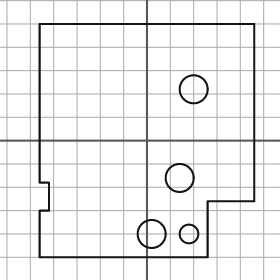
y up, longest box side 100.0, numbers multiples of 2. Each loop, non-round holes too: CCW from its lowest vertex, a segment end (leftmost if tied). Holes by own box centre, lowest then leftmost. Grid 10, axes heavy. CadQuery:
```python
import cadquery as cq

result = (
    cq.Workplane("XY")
    .moveTo(-46.0, -50.0)
    .lineTo(26.0, -50.0)
    .lineTo(26.0, -26.0)
    .lineTo(46.0, -26.0)
    .lineTo(46.0, 50.0)
    .lineTo(-46.0, 50.0)
    .lineTo(-46.0, -18.0)
    .lineTo(-42.0, -18.0)
    .lineTo(-42.0, -30.0)
    .lineTo(-46.0, -30.0)
    .close()
    .moveTo(2.0, -40.0)
    .circle(6.0)
    .moveTo(18.0, -40.0)
    .circle(4.0)
    .moveTo(14.0, -16.0)
    .circle(6.0)
    .moveTo(20.0, 22.0)
    .circle(6.0)
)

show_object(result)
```